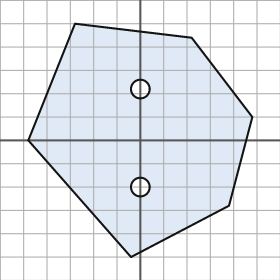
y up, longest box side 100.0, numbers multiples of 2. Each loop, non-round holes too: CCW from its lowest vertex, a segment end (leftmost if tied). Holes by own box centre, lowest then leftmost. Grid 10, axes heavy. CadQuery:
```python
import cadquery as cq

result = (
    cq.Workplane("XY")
    .moveTo(-4.0, -50.0)
    .lineTo(38.0, -28.0)
    .lineTo(48.0, 10.0)
    .lineTo(22.0, 44.0)
    .lineTo(-28.0, 50.0)
    .lineTo(-48.0, 0.0)
    .close()
    .moveTo(0.0, -20.0)
    .circle(4.0)
    .moveTo(0.0, 22.0)
    .circle(4.0)
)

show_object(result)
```